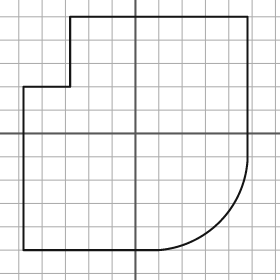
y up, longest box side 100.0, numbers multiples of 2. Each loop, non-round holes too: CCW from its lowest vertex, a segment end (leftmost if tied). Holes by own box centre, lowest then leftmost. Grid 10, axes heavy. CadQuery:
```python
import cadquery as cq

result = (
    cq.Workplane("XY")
    .moveTo(-48.0, -50.0)
    .lineTo(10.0, -50.0)
    .threePointArc((36.0, -38.0), (48.0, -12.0))
    .lineTo(48.0, 50.0)
    .lineTo(-28.0, 50.0)
    .lineTo(-28.0, 20.0)
    .lineTo(-48.0, 20.0)
    .close()
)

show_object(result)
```